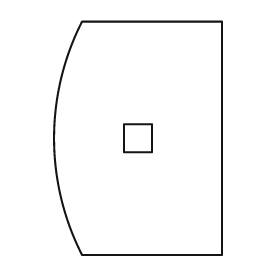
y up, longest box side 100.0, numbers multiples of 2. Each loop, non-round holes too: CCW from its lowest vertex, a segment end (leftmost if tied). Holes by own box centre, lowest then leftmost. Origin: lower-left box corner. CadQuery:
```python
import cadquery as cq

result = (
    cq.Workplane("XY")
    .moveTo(12.0, 0.0)
    .lineTo(72.0, 0.0)
    .lineTo(72.0, 100.0)
    .lineTo(12.0, 100.0)
    .threePointArc((0.0, 50.0), (12.0, 0.0))
    .close()
    .moveTo(30.0, 44.0)
    .lineTo(42.0, 44.0)
    .lineTo(42.0, 56.0)
    .lineTo(30.0, 56.0)
    .close()
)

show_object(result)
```